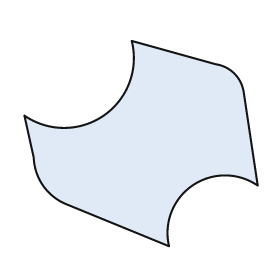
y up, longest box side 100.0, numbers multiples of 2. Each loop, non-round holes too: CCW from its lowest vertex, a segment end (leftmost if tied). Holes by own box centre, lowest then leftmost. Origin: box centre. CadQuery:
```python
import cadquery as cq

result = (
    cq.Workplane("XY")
    .moveTo(12.0, -44.0)
    .threePointArc((22.0, -18.0), (50.0, -18.0))
    .lineTo(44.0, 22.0)
    .threePointArc((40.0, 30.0), (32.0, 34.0))
    .lineTo(-4.0, 44.0)
    .threePointArc((-16.0, 12.0), (-50.0, 12.0))
    .lineTo(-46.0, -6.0)
    .threePointArc((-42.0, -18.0), (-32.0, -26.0))
    .close()
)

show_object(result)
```